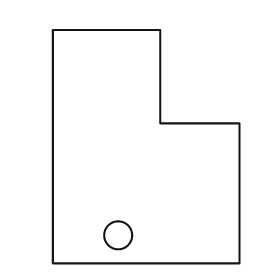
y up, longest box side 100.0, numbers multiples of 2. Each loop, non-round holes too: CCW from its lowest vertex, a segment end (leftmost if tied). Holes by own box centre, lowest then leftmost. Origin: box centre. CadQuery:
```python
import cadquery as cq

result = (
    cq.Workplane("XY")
    .moveTo(-40.0, -50.0)
    .lineTo(40.0, -50.0)
    .lineTo(40.0, 10.0)
    .lineTo(6.0, 10.0)
    .lineTo(6.0, 50.0)
    .lineTo(-40.0, 50.0)
    .close()
    .moveTo(-12.0, -38.0)
    .circle(6.0)
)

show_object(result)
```